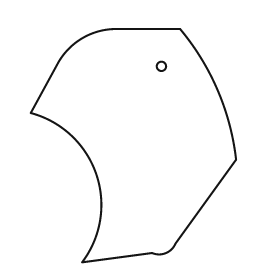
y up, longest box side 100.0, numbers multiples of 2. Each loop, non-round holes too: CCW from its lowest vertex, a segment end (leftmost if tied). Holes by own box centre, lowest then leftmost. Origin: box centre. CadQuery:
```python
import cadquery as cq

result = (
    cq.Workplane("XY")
    .moveTo(-22.0, -50.0)
    .lineTo(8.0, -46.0)
    .threePointArc((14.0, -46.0), (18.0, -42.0))
    .lineTo(44.0, -6.0)
    .threePointArc((36.0, 24.0), (20.0, 50.0))
    .lineTo(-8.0, 50.0)
    .threePointArc((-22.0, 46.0), (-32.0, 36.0))
    .lineTo(-44.0, 14.0)
    .threePointArc((-16.0, -12.0), (-22.0, -50.0))
    .close()
    .moveTo(12.0, 34.0)
    .circle(2.0)
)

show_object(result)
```